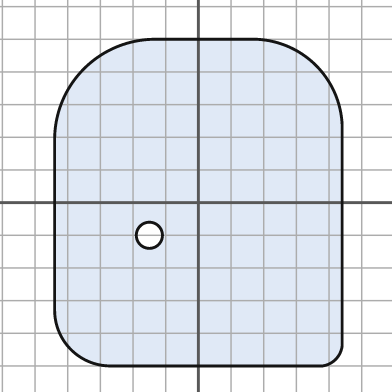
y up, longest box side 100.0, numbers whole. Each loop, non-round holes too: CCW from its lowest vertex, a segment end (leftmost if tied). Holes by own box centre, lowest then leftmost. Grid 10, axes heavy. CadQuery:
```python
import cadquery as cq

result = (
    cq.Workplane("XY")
    .moveTo(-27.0, -50.0)
    .lineTo(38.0, -50.0)
    .threePointArc((42.0, -48.0), (44.0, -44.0))
    .lineTo(44.0, 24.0)
    .threePointArc((36.0, 42.0), (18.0, 50.0))
    .lineTo(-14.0, 50.0)
    .threePointArc((-35.0, 41.0), (-44.0, 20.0))
    .lineTo(-44.0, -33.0)
    .threePointArc((-39.0, -45.0), (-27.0, -50.0))
    .close()
    .moveTo(-15.0, -10.0)
    .circle(4.0)
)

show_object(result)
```